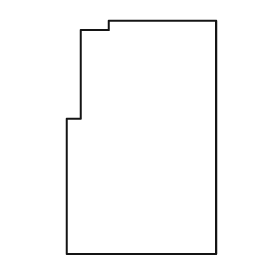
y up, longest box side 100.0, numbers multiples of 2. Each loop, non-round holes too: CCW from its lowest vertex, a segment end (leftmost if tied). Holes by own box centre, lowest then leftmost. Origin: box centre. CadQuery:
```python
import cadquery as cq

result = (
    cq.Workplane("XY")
    .moveTo(-32.0, -50.0)
    .lineTo(32.0, -50.0)
    .lineTo(32.0, 50.0)
    .lineTo(-14.0, 50.0)
    .lineTo(-14.0, 46.0)
    .lineTo(-26.0, 46.0)
    .lineTo(-26.0, 8.0)
    .lineTo(-32.0, 8.0)
    .close()
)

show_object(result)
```